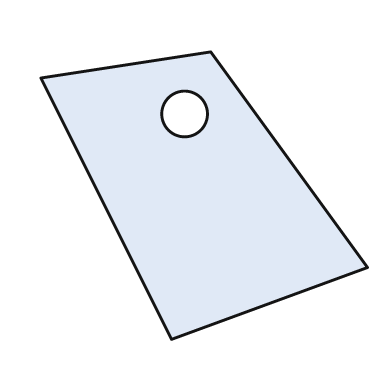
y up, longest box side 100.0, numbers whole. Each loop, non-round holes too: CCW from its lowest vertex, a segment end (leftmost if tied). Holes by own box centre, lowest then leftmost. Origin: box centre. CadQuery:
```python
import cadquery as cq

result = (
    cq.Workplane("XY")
    .moveTo(-10.0, -44.0)
    .lineTo(50.0, -22.0)
    .lineTo(2.0, 44.0)
    .lineTo(-50.0, 36.0)
    .close()
    .moveTo(-6.0, 25.0)
    .circle(7.0)
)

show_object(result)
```